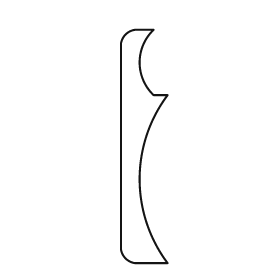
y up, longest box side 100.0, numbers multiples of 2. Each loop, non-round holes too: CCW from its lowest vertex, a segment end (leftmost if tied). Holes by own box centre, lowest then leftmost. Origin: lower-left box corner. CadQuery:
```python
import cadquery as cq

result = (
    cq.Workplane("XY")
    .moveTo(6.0, 0.0)
    .lineTo(20.0, 0.0)
    .threePointArc((8.0, 36.0), (20.0, 72.0))
    .lineTo(14.0, 72.0)
    .threePointArc((8.0, 86.0), (14.0, 100.0))
    .lineTo(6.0, 100.0)
    .threePointArc((2.0, 98.0), (0.0, 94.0))
    .lineTo(0.0, 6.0)
    .threePointArc((2.0, 2.0), (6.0, 0.0))
    .close()
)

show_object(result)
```